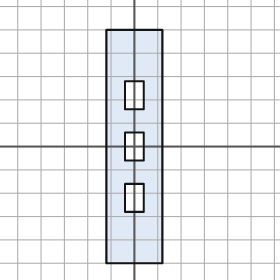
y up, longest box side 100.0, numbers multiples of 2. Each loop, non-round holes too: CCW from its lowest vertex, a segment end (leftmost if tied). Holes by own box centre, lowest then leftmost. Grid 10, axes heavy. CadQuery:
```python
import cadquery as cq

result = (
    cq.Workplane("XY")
    .moveTo(-12.0, -50.0)
    .lineTo(12.0, -50.0)
    .lineTo(12.0, 50.0)
    .lineTo(-12.0, 50.0)
    .close()
    .moveTo(-4.0, -28.0)
    .lineTo(4.0, -28.0)
    .lineTo(4.0, -16.0)
    .lineTo(-4.0, -16.0)
    .close()
    .moveTo(-4.0, -6.0)
    .lineTo(4.0, -6.0)
    .lineTo(4.0, 6.0)
    .lineTo(-4.0, 6.0)
    .close()
    .moveTo(-4.0, 16.0)
    .lineTo(4.0, 16.0)
    .lineTo(4.0, 28.0)
    .lineTo(-4.0, 28.0)
    .close()
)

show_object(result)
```